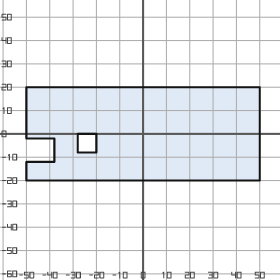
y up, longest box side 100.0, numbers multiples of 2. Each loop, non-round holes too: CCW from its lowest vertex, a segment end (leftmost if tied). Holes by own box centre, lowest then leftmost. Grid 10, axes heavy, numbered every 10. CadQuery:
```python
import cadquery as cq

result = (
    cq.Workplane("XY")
    .moveTo(-50.0, -20.0)
    .lineTo(50.0, -20.0)
    .lineTo(50.0, 20.0)
    .lineTo(-50.0, 20.0)
    .lineTo(-50.0, -2.0)
    .lineTo(-38.0, -2.0)
    .lineTo(-38.0, -12.0)
    .lineTo(-50.0, -12.0)
    .close()
    .moveTo(-28.0, -8.0)
    .lineTo(-20.0, -8.0)
    .lineTo(-20.0, 0.0)
    .lineTo(-28.0, 0.0)
    .close()
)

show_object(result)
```